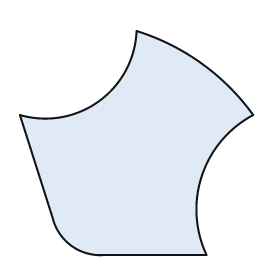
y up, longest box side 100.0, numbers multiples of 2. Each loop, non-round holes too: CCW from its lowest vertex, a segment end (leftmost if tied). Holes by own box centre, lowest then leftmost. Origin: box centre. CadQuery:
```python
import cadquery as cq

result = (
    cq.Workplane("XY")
    .moveTo(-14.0, -48.0)
    .lineTo(30.0, -48.0)
    .threePointArc((28.0, -14.0), (50.0, 12.0))
    .threePointArc((28.0, 34.0), (0.0, 48.0))
    .threePointArc((-16.0, 18.0), (-50.0, 12.0))
    .lineTo(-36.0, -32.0)
    .threePointArc((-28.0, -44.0), (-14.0, -48.0))
    .close()
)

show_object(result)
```